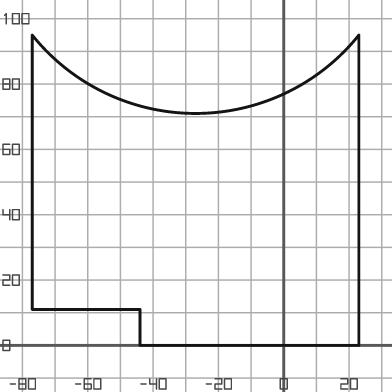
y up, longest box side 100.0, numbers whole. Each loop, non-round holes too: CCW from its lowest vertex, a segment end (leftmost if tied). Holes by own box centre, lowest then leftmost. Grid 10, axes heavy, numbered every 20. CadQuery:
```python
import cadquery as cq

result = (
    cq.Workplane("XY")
    .moveTo(-44.0, 0.0)
    .lineTo(23.0, 0.0)
    .lineTo(23.0, 95.0)
    .threePointArc((-27.0, 71.0), (-77.0, 95.0))
    .lineTo(-77.0, 11.0)
    .lineTo(-44.0, 11.0)
    .close()
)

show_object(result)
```